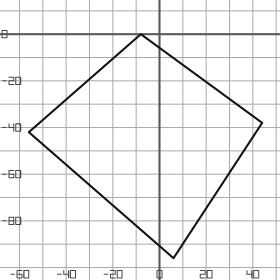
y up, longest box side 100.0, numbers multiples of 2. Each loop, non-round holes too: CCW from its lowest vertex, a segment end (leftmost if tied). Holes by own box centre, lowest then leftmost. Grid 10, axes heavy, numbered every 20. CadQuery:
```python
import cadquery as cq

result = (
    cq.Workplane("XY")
    .moveTo(6.0, -96.0)
    .lineTo(44.0, -38.0)
    .lineTo(-8.0, 0.0)
    .lineTo(-56.0, -42.0)
    .close()
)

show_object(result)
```